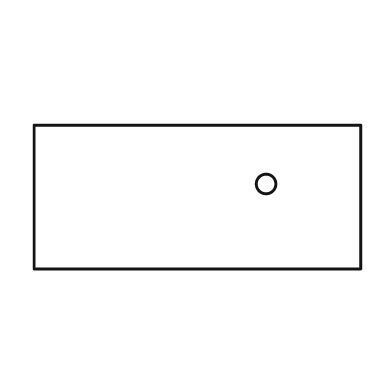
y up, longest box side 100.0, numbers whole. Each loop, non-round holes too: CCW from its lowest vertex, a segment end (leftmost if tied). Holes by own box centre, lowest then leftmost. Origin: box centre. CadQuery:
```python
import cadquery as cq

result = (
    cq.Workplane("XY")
    .moveTo(-50.0, -22.0)
    .lineTo(50.0, -22.0)
    .lineTo(50.0, 22.0)
    .lineTo(-50.0, 22.0)
    .close()
    .moveTo(21.0, 4.0)
    .circle(3.0)
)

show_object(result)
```